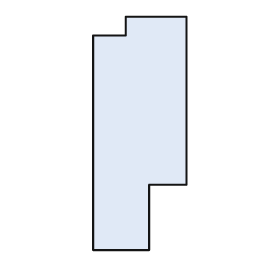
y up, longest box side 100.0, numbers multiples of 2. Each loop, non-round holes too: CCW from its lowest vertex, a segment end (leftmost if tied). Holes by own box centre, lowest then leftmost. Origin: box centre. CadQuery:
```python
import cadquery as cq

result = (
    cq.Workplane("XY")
    .moveTo(-20.0, -50.0)
    .lineTo(4.0, -50.0)
    .lineTo(4.0, -22.0)
    .lineTo(20.0, -22.0)
    .lineTo(20.0, 50.0)
    .lineTo(-6.0, 50.0)
    .lineTo(-6.0, 42.0)
    .lineTo(-20.0, 42.0)
    .close()
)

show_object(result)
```